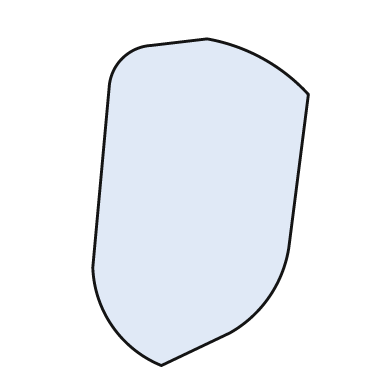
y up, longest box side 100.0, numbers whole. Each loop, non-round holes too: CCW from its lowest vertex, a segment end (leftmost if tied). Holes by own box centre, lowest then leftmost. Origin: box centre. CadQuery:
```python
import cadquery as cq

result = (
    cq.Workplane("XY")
    .moveTo(-12.0, -50.0)
    .lineTo(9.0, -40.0)
    .threePointArc((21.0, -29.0), (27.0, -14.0))
    .lineTo(33.0, 33.0)
    .threePointArc((19.0, 44.0), (2.0, 50.0))
    .lineTo(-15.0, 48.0)
    .threePointArc((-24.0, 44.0), (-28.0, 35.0))
    .lineTo(-33.0, -20.0)
    .threePointArc((-27.0, -38.0), (-12.0, -50.0))
    .close()
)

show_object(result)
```